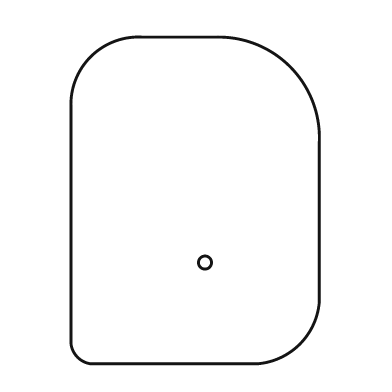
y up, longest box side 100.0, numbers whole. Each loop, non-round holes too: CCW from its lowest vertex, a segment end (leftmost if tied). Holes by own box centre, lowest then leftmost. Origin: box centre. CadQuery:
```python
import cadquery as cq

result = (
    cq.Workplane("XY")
    .moveTo(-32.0, -50.0)
    .lineTo(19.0, -50.0)
    .threePointArc((32.0, -44.0), (38.0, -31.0))
    .lineTo(38.0, 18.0)
    .threePointArc((29.0, 41.0), (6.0, 50.0))
    .lineTo(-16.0, 50.0)
    .threePointArc((-32.0, 44.0), (-38.0, 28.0))
    .lineTo(-38.0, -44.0)
    .threePointArc((-36.0, -48.0), (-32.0, -50.0))
    .close()
    .moveTo(3.0, -19.0)
    .circle(2.0)
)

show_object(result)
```